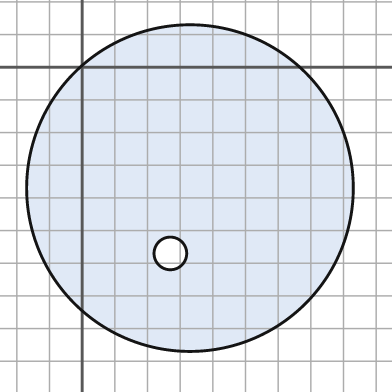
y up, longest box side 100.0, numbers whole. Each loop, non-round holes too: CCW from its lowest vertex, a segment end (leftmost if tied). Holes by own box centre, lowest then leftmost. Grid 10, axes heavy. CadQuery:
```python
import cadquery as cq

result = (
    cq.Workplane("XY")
    .moveTo(33.0, -37.0)
    .circle(50.0)
    .moveTo(27.0, -57.0)
    .circle(5.0)
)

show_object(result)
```